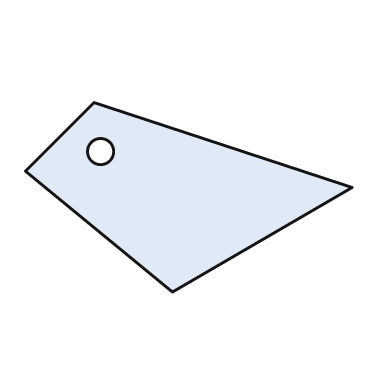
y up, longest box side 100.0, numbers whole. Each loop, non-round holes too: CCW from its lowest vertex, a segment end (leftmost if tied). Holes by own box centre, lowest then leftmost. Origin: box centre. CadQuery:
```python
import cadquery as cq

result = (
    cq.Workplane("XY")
    .moveTo(-5.0, -29.0)
    .lineTo(50.0, 3.0)
    .lineTo(-29.0, 29.0)
    .lineTo(-50.0, 8.0)
    .close()
    .moveTo(-27.0, 14.0)
    .circle(4.0)
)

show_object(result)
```